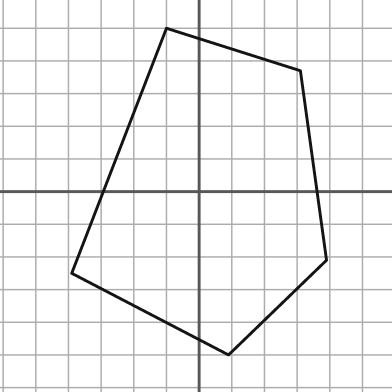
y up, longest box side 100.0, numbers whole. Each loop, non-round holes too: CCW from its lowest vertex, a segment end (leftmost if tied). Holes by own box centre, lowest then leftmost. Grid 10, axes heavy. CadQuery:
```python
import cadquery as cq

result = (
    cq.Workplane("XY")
    .moveTo(9.0, -50.0)
    .lineTo(39.0, -21.0)
    .lineTo(31.0, 37.0)
    .lineTo(-10.0, 50.0)
    .lineTo(-39.0, -25.0)
    .close()
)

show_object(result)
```